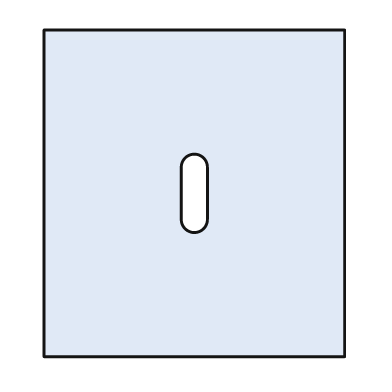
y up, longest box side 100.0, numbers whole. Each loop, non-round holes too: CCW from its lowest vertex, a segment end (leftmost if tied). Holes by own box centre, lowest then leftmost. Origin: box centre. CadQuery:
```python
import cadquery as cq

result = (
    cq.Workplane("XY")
    .moveTo(-46.0, -50.0)
    .lineTo(46.0, -50.0)
    .lineTo(46.0, 50.0)
    .lineTo(-46.0, 50.0)
    .close()
    .moveTo(-4.0, -8.0)
    .threePointArc((0.0, -12.0), (4.0, -8.0))
    .lineTo(4.0, 8.0)
    .threePointArc((0.0, 12.0), (-4.0, 8.0))
    .close()
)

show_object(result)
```